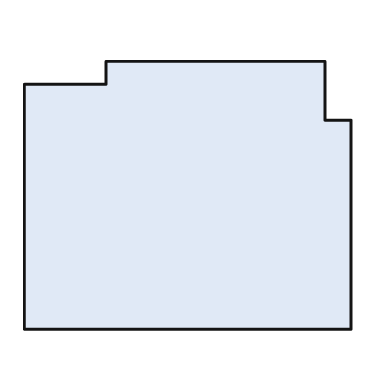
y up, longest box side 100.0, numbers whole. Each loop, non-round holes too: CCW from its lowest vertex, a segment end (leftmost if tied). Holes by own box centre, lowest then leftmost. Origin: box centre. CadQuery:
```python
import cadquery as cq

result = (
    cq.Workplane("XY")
    .moveTo(-50.0, -41.0)
    .lineTo(50.0, -41.0)
    .lineTo(50.0, 23.0)
    .lineTo(42.0, 23.0)
    .lineTo(42.0, 41.0)
    .lineTo(-25.0, 41.0)
    .lineTo(-25.0, 34.0)
    .lineTo(-50.0, 34.0)
    .close()
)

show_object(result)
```